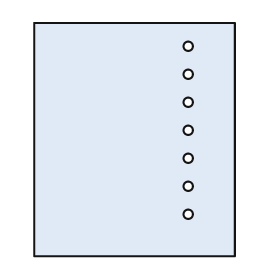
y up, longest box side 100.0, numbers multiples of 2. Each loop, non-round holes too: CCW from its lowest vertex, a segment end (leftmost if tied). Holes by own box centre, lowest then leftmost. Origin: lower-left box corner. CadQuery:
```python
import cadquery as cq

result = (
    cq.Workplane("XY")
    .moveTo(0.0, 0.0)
    .lineTo(86.0, 0.0)
    .lineTo(86.0, 100.0)
    .lineTo(0.0, 100.0)
    .close()
    .moveTo(66.0, 18.0)
    .circle(2.0)
    .moveTo(66.0, 30.0)
    .circle(2.0)
    .moveTo(66.0, 42.0)
    .circle(2.0)
    .moveTo(66.0, 54.0)
    .circle(2.0)
    .moveTo(66.0, 66.0)
    .circle(2.0)
    .moveTo(66.0, 78.0)
    .circle(2.0)
    .moveTo(66.0, 90.0)
    .circle(2.0)
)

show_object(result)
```